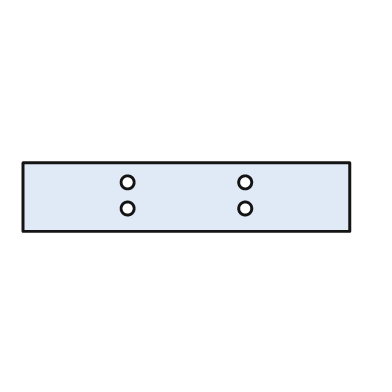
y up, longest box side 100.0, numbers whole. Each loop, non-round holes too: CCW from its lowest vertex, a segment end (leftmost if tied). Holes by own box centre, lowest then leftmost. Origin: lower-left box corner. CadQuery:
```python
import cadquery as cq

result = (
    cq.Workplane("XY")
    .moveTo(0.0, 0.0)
    .lineTo(100.0, 0.0)
    .lineTo(100.0, 21.0)
    .lineTo(0.0, 21.0)
    .close()
    .moveTo(32.0, 7.0)
    .circle(2.0)
    .moveTo(68.0, 7.0)
    .circle(2.0)
    .moveTo(32.0, 15.0)
    .circle(2.0)
    .moveTo(68.0, 15.0)
    .circle(2.0)
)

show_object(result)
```